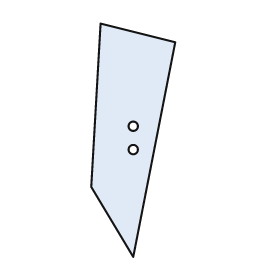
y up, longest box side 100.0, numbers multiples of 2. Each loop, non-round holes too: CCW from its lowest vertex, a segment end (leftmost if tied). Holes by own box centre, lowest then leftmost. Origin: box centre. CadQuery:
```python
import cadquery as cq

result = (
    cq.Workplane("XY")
    .moveTo(0.0, -50.0)
    .lineTo(18.0, 42.0)
    .lineTo(-14.0, 50.0)
    .lineTo(-18.0, -20.0)
    .close()
    .moveTo(0.0, -4.0)
    .circle(2.0)
    .moveTo(0.0, 6.0)
    .circle(2.0)
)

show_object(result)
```